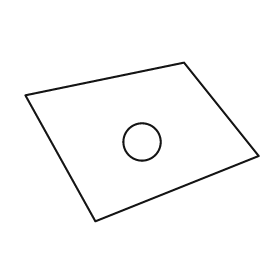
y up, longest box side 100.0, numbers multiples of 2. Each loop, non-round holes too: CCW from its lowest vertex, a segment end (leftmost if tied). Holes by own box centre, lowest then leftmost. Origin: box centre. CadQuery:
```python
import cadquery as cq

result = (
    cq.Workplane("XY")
    .moveTo(-20.0, -34.0)
    .lineTo(50.0, -6.0)
    .lineTo(18.0, 34.0)
    .lineTo(-50.0, 20.0)
    .close()
    .moveTo(0.0, 0.0)
    .circle(8.0)
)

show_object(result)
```